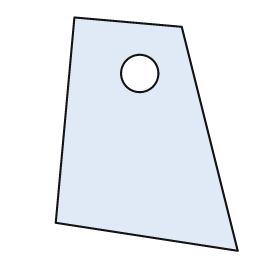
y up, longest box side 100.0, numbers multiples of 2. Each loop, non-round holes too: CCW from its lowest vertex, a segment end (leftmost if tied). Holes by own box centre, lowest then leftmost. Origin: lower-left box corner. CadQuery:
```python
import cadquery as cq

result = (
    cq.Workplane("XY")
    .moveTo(78.0, 0.0)
    .lineTo(54.0, 96.0)
    .lineTo(8.0, 100.0)
    .lineTo(0.0, 12.0)
    .close()
    .moveTo(36.0, 76.0)
    .circle(8.0)
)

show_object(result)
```